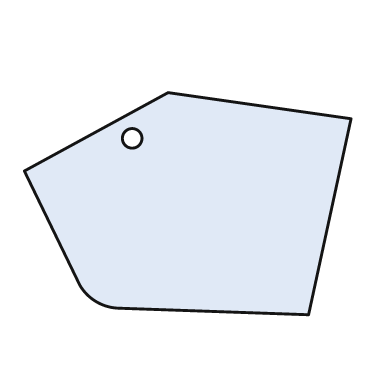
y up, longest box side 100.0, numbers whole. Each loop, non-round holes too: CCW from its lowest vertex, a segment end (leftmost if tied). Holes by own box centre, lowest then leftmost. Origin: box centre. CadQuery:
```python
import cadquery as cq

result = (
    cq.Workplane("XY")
    .moveTo(37.0, -34.0)
    .lineTo(50.0, 26.0)
    .lineTo(-6.0, 34.0)
    .lineTo(-50.0, 10.0)
    .lineTo(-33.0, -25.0)
    .threePointArc((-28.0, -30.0), (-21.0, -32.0))
    .close()
    .moveTo(-17.0, 20.0)
    .circle(3.0)
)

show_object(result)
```